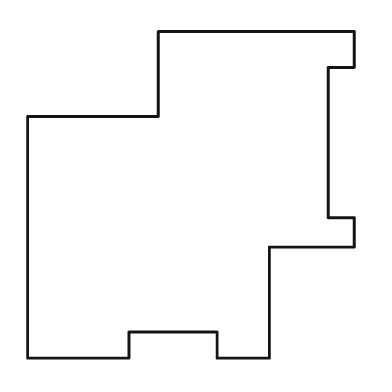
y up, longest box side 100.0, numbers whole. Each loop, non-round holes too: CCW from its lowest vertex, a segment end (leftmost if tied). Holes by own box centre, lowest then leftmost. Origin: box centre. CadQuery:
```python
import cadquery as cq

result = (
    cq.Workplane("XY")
    .moveTo(-50.0, -50.0)
    .lineTo(-19.0, -50.0)
    .lineTo(-19.0, -42.0)
    .lineTo(8.0, -42.0)
    .lineTo(8.0, -50.0)
    .lineTo(24.0, -50.0)
    .lineTo(24.0, -16.0)
    .lineTo(50.0, -16.0)
    .lineTo(50.0, -7.0)
    .lineTo(42.0, -7.0)
    .lineTo(42.0, 39.0)
    .lineTo(50.0, 39.0)
    .lineTo(50.0, 50.0)
    .lineTo(-10.0, 50.0)
    .lineTo(-10.0, 24.0)
    .lineTo(-50.0, 24.0)
    .close()
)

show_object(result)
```